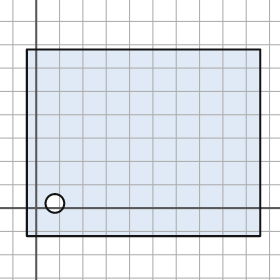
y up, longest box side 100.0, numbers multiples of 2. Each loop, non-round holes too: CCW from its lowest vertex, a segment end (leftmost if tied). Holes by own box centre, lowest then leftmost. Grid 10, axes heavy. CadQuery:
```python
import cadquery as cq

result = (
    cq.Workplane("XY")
    .moveTo(-4.0, -12.0)
    .lineTo(96.0, -12.0)
    .lineTo(96.0, 68.0)
    .lineTo(-4.0, 68.0)
    .close()
    .moveTo(8.0, 2.0)
    .circle(4.0)
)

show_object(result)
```